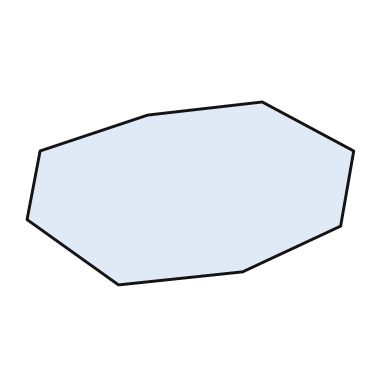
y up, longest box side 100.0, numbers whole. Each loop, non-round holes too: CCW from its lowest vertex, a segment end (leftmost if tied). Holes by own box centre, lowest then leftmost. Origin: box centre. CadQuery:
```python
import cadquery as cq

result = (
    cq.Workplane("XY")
    .moveTo(-22.0, -28.0)
    .lineTo(16.0, -24.0)
    .lineTo(46.0, -10.0)
    .lineTo(50.0, 13.0)
    .lineTo(22.0, 28.0)
    .lineTo(-13.0, 24.0)
    .lineTo(-46.0, 13.0)
    .lineTo(-50.0, -8.0)
    .close()
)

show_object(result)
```